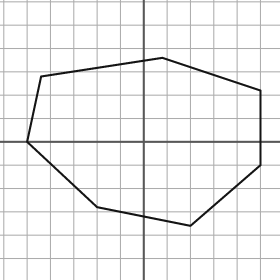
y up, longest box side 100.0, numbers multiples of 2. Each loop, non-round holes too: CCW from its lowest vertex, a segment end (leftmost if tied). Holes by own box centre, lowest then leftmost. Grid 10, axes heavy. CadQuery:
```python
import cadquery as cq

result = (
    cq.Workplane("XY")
    .moveTo(20.0, -36.0)
    .lineTo(50.0, -10.0)
    .lineTo(50.0, 22.0)
    .lineTo(8.0, 36.0)
    .lineTo(-44.0, 28.0)
    .lineTo(-50.0, 0.0)
    .lineTo(-20.0, -28.0)
    .close()
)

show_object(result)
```